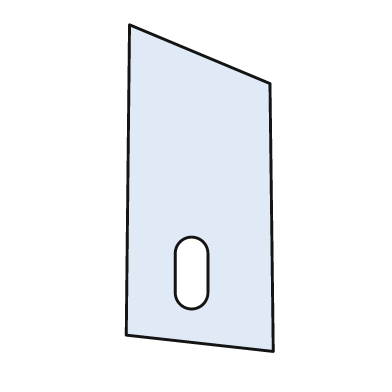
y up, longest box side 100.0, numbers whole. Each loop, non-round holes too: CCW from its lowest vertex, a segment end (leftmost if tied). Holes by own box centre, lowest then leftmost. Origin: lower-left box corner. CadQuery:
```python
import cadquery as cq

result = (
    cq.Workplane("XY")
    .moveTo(45.0, 0.0)
    .lineTo(44.0, 82.0)
    .lineTo(1.0, 100.0)
    .lineTo(0.0, 5.0)
    .close()
    .moveTo(15.0, 18.0)
    .threePointArc((20.0, 13.0), (25.0, 18.0))
    .lineTo(25.0, 30.0)
    .threePointArc((20.0, 35.0), (15.0, 30.0))
    .close()
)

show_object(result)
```